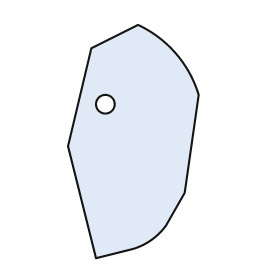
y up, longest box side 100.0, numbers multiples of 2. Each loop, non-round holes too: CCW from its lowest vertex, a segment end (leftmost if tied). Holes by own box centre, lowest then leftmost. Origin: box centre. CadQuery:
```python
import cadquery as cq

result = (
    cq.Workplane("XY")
    .moveTo(-16.0, -50.0)
    .lineTo(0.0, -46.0)
    .threePointArc((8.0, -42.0), (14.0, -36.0))
    .lineTo(22.0, -22.0)
    .lineTo(28.0, 20.0)
    .threePointArc((18.0, 38.0), (2.0, 50.0))
    .lineTo(-18.0, 40.0)
    .lineTo(-28.0, -2.0)
    .close()
    .moveTo(-12.0, 16.0)
    .circle(4.0)
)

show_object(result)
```